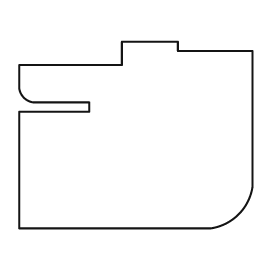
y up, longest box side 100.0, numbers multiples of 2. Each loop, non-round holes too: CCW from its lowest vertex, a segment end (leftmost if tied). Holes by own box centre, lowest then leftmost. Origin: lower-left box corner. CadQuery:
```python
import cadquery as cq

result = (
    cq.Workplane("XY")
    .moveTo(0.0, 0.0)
    .lineTo(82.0, 0.0)
    .threePointArc((94.0, 6.0), (100.0, 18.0))
    .lineTo(100.0, 76.0)
    .lineTo(68.0, 76.0)
    .lineTo(68.0, 80.0)
    .lineTo(44.0, 80.0)
    .lineTo(44.0, 70.0)
    .lineTo(0.0, 70.0)
    .lineTo(0.0, 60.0)
    .threePointArc((2.0, 56.0), (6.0, 54.0))
    .lineTo(30.0, 54.0)
    .lineTo(30.0, 50.0)
    .lineTo(0.0, 50.0)
    .close()
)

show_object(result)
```